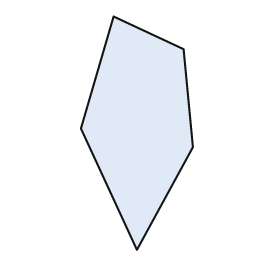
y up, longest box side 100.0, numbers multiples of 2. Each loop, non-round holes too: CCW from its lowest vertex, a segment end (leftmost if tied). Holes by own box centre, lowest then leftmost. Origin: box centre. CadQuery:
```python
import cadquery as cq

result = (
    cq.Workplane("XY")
    .moveTo(0.0, -50.0)
    .lineTo(24.0, -6.0)
    .lineTo(20.0, 36.0)
    .lineTo(-10.0, 50.0)
    .lineTo(-24.0, 2.0)
    .close()
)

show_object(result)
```